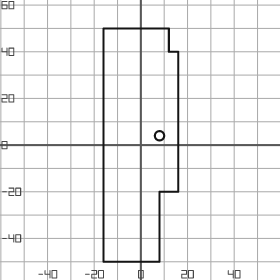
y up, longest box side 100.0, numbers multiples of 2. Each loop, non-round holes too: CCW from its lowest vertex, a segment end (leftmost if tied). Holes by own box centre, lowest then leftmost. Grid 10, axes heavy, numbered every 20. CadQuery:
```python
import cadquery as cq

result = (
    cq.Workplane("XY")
    .moveTo(-16.0, -50.0)
    .lineTo(8.0, -50.0)
    .lineTo(8.0, -20.0)
    .lineTo(16.0, -20.0)
    .lineTo(16.0, 40.0)
    .lineTo(12.0, 40.0)
    .lineTo(12.0, 50.0)
    .lineTo(-16.0, 50.0)
    .close()
    .moveTo(8.0, 4.0)
    .circle(2.0)
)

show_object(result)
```